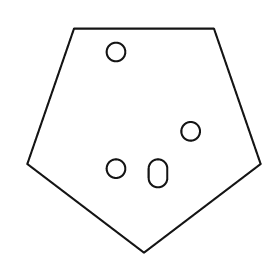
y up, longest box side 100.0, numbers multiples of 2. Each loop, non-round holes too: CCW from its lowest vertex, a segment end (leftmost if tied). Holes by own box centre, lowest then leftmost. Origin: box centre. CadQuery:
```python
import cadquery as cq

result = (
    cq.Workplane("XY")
    .moveTo(0.0, -48.0)
    .lineTo(50.0, -10.0)
    .lineTo(30.0, 48.0)
    .lineTo(-30.0, 48.0)
    .lineTo(-50.0, -10.0)
    .close()
    .moveTo(2.0, -16.0)
    .threePointArc((6.0, -20.0), (10.0, -16.0))
    .lineTo(10.0, -12.0)
    .threePointArc((6.0, -8.0), (2.0, -12.0))
    .close()
    .moveTo(-12.0, -12.0)
    .circle(4.0)
    .moveTo(20.0, 4.0)
    .circle(4.0)
    .moveTo(-12.0, 38.0)
    .circle(4.0)
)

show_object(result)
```